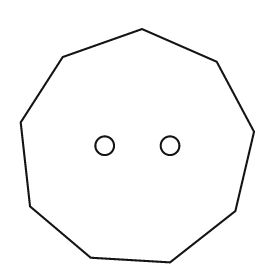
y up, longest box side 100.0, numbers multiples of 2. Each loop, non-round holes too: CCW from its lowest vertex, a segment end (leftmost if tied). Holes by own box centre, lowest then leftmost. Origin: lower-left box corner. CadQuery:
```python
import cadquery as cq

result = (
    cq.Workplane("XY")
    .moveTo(64.0, 0.0)
    .lineTo(92.0, 22.0)
    .lineTo(100.0, 56.0)
    .lineTo(84.0, 86.0)
    .lineTo(52.0, 100.0)
    .lineTo(18.0, 88.0)
    .lineTo(0.0, 60.0)
    .lineTo(4.0, 24.0)
    .lineTo(30.0, 2.0)
    .close()
    .moveTo(36.0, 50.0)
    .circle(4.0)
    .moveTo(64.0, 50.0)
    .circle(4.0)
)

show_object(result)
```